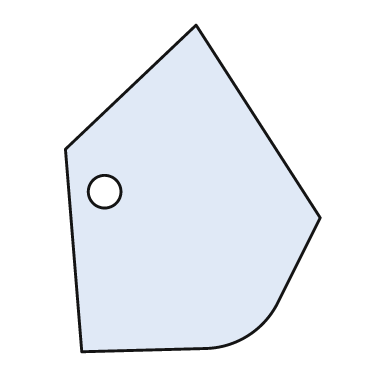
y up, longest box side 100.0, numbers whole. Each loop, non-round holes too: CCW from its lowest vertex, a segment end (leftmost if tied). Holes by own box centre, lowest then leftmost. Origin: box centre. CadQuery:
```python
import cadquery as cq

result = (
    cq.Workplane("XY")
    .moveTo(-34.0, -50.0)
    .lineTo(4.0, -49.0)
    .threePointArc((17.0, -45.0), (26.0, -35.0))
    .lineTo(39.0, -9.0)
    .lineTo(1.0, 50.0)
    .lineTo(-39.0, 12.0)
    .close()
    .moveTo(-27.0, -1.0)
    .circle(5.0)
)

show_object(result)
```